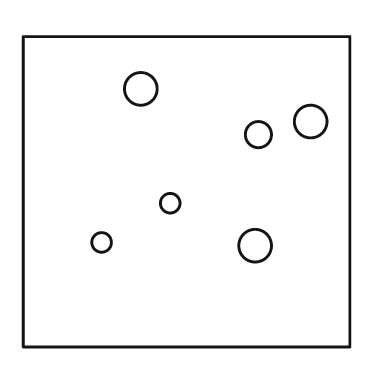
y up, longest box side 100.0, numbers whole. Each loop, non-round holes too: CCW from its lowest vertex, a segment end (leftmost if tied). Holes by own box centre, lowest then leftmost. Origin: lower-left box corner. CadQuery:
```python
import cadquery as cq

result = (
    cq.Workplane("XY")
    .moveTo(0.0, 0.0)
    .lineTo(100.0, 0.0)
    .lineTo(100.0, 95.0)
    .lineTo(0.0, 95.0)
    .close()
    .moveTo(71.0, 31.0)
    .circle(5.0)
    .moveTo(24.0, 32.0)
    .circle(3.0)
    .moveTo(45.0, 44.0)
    .circle(3.0)
    .moveTo(72.0, 65.0)
    .circle(4.0)
    .moveTo(88.0, 69.0)
    .circle(5.0)
    .moveTo(36.0, 79.0)
    .circle(5.0)
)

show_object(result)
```